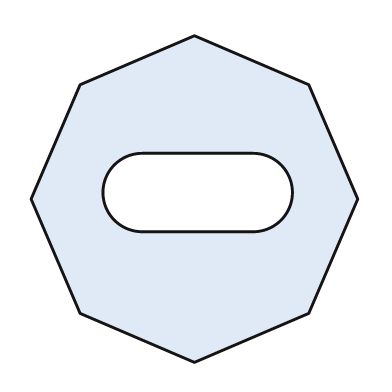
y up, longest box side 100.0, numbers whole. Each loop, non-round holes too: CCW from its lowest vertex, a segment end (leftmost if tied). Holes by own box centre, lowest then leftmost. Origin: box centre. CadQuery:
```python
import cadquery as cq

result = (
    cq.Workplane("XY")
    .moveTo(0.0, -50.0)
    .lineTo(35.0, -35.0)
    .lineTo(50.0, 0.0)
    .lineTo(35.0, 35.0)
    .lineTo(0.0, 50.0)
    .lineTo(-35.0, 35.0)
    .lineTo(-50.0, 0.0)
    .lineTo(-35.0, -35.0)
    .close()
    .moveTo(-16.0, -10.0)
    .lineTo(18.0, -10.0)
    .threePointArc((30.0, 2.0), (18.0, 14.0))
    .lineTo(-16.0, 14.0)
    .threePointArc((-28.0, 2.0), (-16.0, -10.0))
    .close()
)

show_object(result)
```